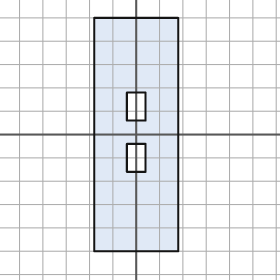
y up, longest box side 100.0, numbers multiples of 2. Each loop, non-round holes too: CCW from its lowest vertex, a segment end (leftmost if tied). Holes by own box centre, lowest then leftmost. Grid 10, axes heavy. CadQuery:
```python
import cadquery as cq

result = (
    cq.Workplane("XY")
    .moveTo(-18.0, -50.0)
    .lineTo(18.0, -50.0)
    .lineTo(18.0, 50.0)
    .lineTo(-18.0, 50.0)
    .close()
    .moveTo(-4.0, -16.0)
    .lineTo(4.0, -16.0)
    .lineTo(4.0, -4.0)
    .lineTo(-4.0, -4.0)
    .close()
    .moveTo(-4.0, 6.0)
    .lineTo(4.0, 6.0)
    .lineTo(4.0, 18.0)
    .lineTo(-4.0, 18.0)
    .close()
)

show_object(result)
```